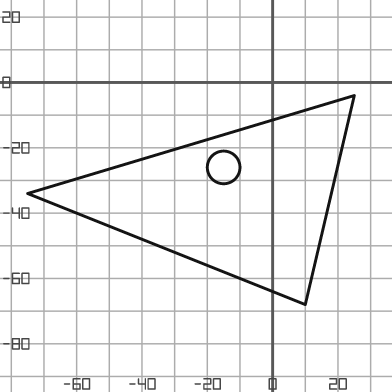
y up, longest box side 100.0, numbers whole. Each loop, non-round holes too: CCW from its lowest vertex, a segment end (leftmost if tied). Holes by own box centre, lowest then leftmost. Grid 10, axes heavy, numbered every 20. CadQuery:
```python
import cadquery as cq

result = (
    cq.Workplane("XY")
    .moveTo(10.0, -68.0)
    .lineTo(25.0, -4.0)
    .lineTo(-75.0, -34.0)
    .close()
    .moveTo(-15.0, -26.0)
    .circle(5.0)
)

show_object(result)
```